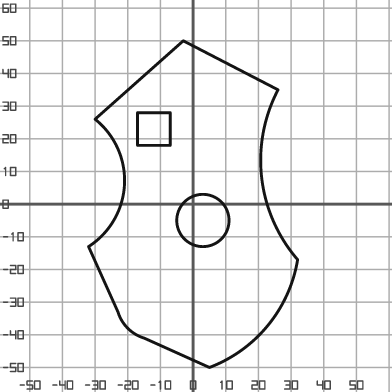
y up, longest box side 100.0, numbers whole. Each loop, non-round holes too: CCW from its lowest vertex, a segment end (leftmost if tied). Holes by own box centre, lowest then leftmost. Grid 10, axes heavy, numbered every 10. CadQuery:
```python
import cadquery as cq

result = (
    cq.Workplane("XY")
    .moveTo(5.0, -50.0)
    .threePointArc((23.0, -37.0), (32.0, -17.0))
    .threePointArc((21.0, 8.0), (26.0, 35.0))
    .lineTo(-3.0, 50.0)
    .lineTo(-30.0, 26.0)
    .threePointArc((-21.0, 6.0), (-32.0, -13.0))
    .lineTo(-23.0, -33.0)
    .threePointArc((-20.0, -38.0), (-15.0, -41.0))
    .close()
    .moveTo(3.0, -5.0)
    .circle(8.0)
    .moveTo(-17.0, 18.0)
    .lineTo(-7.0, 18.0)
    .lineTo(-7.0, 28.0)
    .lineTo(-17.0, 28.0)
    .close()
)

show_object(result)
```